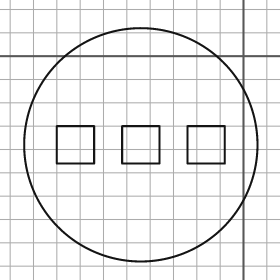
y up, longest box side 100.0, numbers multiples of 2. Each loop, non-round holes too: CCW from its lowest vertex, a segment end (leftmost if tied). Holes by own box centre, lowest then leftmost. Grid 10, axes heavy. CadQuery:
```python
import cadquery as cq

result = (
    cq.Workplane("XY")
    .moveTo(-44.0, -38.0)
    .circle(50.0)
    .moveTo(-80.0, -46.0)
    .lineTo(-64.0, -46.0)
    .lineTo(-64.0, -30.0)
    .lineTo(-80.0, -30.0)
    .close()
    .moveTo(-52.0, -46.0)
    .lineTo(-36.0, -46.0)
    .lineTo(-36.0, -30.0)
    .lineTo(-52.0, -30.0)
    .close()
    .moveTo(-24.0, -46.0)
    .lineTo(-8.0, -46.0)
    .lineTo(-8.0, -30.0)
    .lineTo(-24.0, -30.0)
    .close()
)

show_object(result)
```